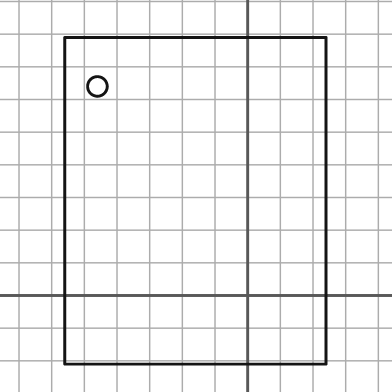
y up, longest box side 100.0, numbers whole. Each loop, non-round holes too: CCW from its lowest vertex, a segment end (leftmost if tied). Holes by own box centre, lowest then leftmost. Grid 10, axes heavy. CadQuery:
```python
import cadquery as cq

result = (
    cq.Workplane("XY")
    .moveTo(-56.0, -21.0)
    .lineTo(24.0, -21.0)
    .lineTo(24.0, 79.0)
    .lineTo(-56.0, 79.0)
    .close()
    .moveTo(-46.0, 64.0)
    .circle(3.0)
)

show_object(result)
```